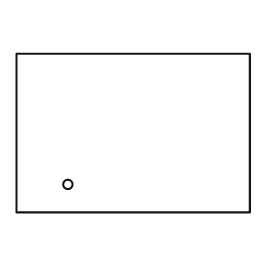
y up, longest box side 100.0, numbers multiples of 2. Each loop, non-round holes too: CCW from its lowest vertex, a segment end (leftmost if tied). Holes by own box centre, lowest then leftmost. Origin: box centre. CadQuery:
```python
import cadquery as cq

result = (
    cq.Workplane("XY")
    .moveTo(-50.0, -34.0)
    .lineTo(50.0, -34.0)
    .lineTo(50.0, 34.0)
    .lineTo(-50.0, 34.0)
    .close()
    .moveTo(-28.0, -22.0)
    .circle(2.0)
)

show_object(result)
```